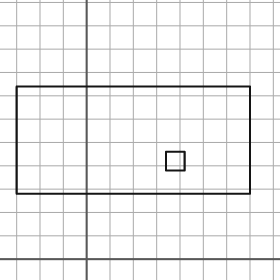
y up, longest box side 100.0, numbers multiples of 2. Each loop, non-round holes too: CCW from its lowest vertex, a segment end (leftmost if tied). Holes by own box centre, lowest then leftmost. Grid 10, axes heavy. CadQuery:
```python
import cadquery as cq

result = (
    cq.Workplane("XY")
    .moveTo(-30.0, 28.0)
    .lineTo(70.0, 28.0)
    .lineTo(70.0, 74.0)
    .lineTo(-30.0, 74.0)
    .close()
    .moveTo(34.0, 38.0)
    .lineTo(42.0, 38.0)
    .lineTo(42.0, 46.0)
    .lineTo(34.0, 46.0)
    .close()
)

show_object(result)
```